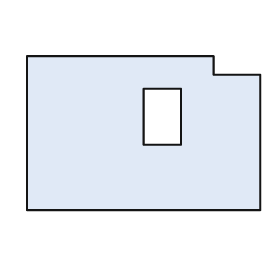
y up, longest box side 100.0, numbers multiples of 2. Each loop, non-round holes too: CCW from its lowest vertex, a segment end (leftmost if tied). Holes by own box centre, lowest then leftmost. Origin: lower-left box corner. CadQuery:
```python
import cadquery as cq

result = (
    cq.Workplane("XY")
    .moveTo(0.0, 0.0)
    .lineTo(100.0, 0.0)
    .lineTo(100.0, 58.0)
    .lineTo(80.0, 58.0)
    .lineTo(80.0, 66.0)
    .lineTo(0.0, 66.0)
    .close()
    .moveTo(50.0, 28.0)
    .lineTo(66.0, 28.0)
    .lineTo(66.0, 52.0)
    .lineTo(50.0, 52.0)
    .close()
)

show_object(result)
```